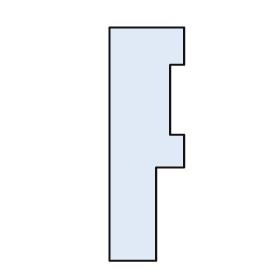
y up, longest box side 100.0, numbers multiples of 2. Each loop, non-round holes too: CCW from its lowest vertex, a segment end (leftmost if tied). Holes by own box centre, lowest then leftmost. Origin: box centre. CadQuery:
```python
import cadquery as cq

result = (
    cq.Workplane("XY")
    .moveTo(-16.0, -50.0)
    .lineTo(4.0, -50.0)
    .lineTo(4.0, -10.0)
    .lineTo(16.0, -10.0)
    .lineTo(16.0, 4.0)
    .lineTo(10.0, 4.0)
    .lineTo(10.0, 34.0)
    .lineTo(16.0, 34.0)
    .lineTo(16.0, 50.0)
    .lineTo(-16.0, 50.0)
    .close()
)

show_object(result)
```